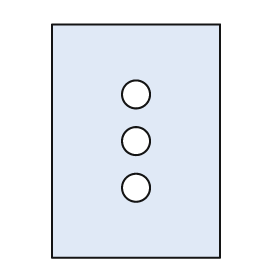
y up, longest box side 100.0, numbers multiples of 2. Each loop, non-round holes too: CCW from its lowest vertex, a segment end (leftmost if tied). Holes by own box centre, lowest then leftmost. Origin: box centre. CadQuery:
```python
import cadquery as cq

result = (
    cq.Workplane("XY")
    .moveTo(-36.0, -50.0)
    .lineTo(36.0, -50.0)
    .lineTo(36.0, 50.0)
    .lineTo(-36.0, 50.0)
    .close()
    .moveTo(0.0, -20.0)
    .circle(6.0)
    .moveTo(0.0, 0.0)
    .circle(6.0)
    .moveTo(0.0, 20.0)
    .circle(6.0)
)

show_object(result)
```